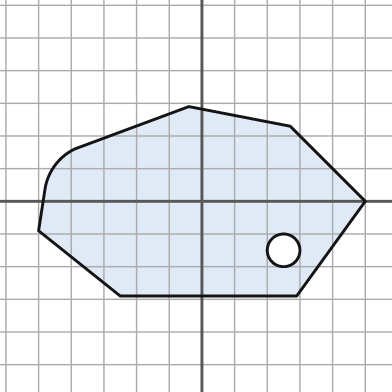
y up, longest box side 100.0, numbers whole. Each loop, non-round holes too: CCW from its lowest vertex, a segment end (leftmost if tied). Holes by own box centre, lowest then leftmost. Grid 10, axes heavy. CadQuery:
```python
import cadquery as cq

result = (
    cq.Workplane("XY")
    .moveTo(-25.0, -29.0)
    .lineTo(29.0, -29.0)
    .lineTo(50.0, 0.0)
    .lineTo(27.0, 23.0)
    .lineTo(-4.0, 29.0)
    .lineTo(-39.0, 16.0)
    .threePointArc((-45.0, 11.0), (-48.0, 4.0))
    .lineTo(-50.0, -9.0)
    .close()
    .moveTo(25.0, -15.0)
    .circle(5.0)
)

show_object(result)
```